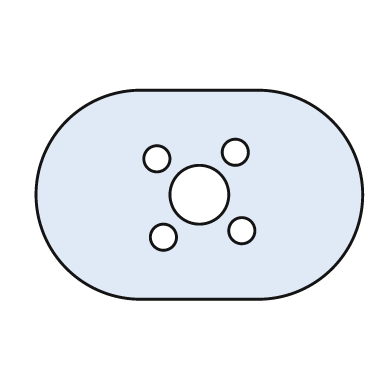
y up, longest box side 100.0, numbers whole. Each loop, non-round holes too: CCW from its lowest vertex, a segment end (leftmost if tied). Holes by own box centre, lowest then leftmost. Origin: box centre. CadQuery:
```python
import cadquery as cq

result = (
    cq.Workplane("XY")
    .moveTo(-18.0, -32.0)
    .lineTo(18.0, -32.0)
    .threePointArc((50.0, 0.0), (18.0, 32.0))
    .lineTo(-18.0, 32.0)
    .threePointArc((-50.0, 0.0), (-18.0, -32.0))
    .close()
    .moveTo(-11.0, -13.0)
    .circle(4.0)
    .moveTo(13.0, -11.0)
    .circle(4.0)
    .moveTo(0.0, 0.0)
    .circle(9.0)
    .moveTo(-13.0, 11.0)
    .circle(4.0)
    .moveTo(11.0, 13.0)
    .circle(4.0)
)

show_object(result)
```